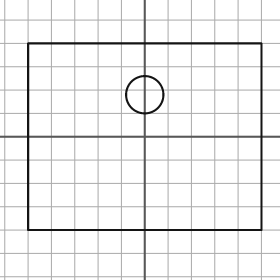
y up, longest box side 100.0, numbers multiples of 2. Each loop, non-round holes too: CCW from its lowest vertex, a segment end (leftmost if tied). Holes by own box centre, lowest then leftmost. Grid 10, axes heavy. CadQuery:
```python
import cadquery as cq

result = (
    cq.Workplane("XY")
    .moveTo(-50.0, -40.0)
    .lineTo(50.0, -40.0)
    .lineTo(50.0, 40.0)
    .lineTo(-50.0, 40.0)
    .close()
    .moveTo(0.0, 18.0)
    .circle(8.0)
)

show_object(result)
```